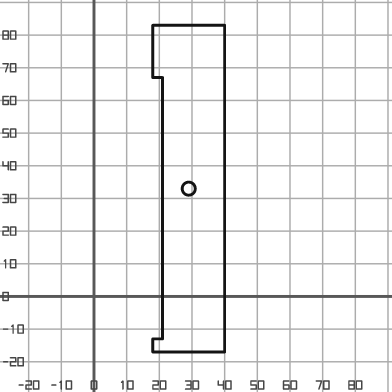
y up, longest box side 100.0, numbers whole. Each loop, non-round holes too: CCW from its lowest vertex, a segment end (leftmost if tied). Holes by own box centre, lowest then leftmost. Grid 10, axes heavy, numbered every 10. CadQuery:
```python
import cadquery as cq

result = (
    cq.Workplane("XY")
    .moveTo(18.0, -17.0)
    .lineTo(40.0, -17.0)
    .lineTo(40.0, 83.0)
    .lineTo(18.0, 83.0)
    .lineTo(18.0, 67.0)
    .lineTo(21.0, 67.0)
    .lineTo(21.0, -13.0)
    .lineTo(18.0, -13.0)
    .close()
    .moveTo(29.0, 33.0)
    .circle(2.0)
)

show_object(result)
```